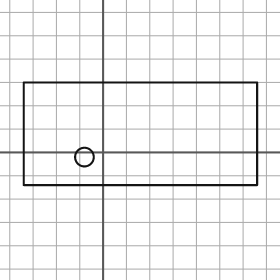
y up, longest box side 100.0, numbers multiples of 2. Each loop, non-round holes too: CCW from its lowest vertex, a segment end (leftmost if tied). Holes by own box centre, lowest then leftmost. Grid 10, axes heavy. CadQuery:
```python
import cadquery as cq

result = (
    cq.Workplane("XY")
    .moveTo(-34.0, -14.0)
    .lineTo(66.0, -14.0)
    .lineTo(66.0, 30.0)
    .lineTo(-34.0, 30.0)
    .close()
    .moveTo(-8.0, -2.0)
    .circle(4.0)
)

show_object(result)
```